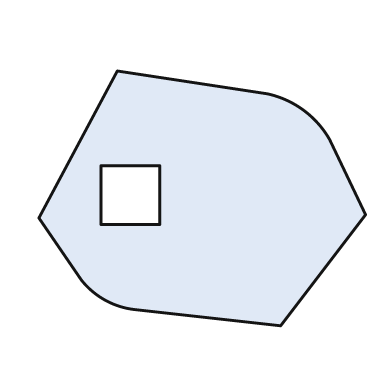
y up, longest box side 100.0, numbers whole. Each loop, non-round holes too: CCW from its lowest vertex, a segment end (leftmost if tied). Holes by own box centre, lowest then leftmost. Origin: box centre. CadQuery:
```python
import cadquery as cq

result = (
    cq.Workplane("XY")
    .moveTo(24.0, -39.0)
    .lineTo(50.0, -5.0)
    .lineTo(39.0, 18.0)
    .threePointArc((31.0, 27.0), (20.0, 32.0))
    .lineTo(-26.0, 39.0)
    .lineTo(-50.0, -6.0)
    .lineTo(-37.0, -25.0)
    .threePointArc((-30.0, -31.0), (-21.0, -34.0))
    .close()
    .moveTo(-31.0, -8.0)
    .lineTo(-13.0, -8.0)
    .lineTo(-13.0, 10.0)
    .lineTo(-31.0, 10.0)
    .close()
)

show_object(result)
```